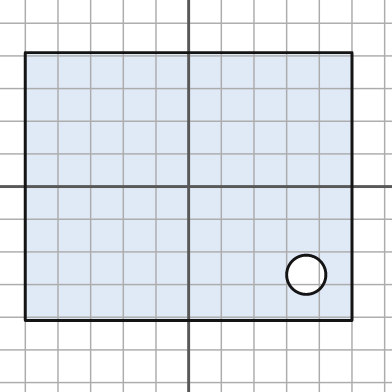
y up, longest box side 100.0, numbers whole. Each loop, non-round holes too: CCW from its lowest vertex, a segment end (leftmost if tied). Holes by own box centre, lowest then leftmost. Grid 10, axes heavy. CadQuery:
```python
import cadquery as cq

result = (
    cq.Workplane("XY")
    .moveTo(-50.0, -41.0)
    .lineTo(50.0, -41.0)
    .lineTo(50.0, 41.0)
    .lineTo(-50.0, 41.0)
    .close()
    .moveTo(36.0, -27.0)
    .circle(6.0)
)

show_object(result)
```